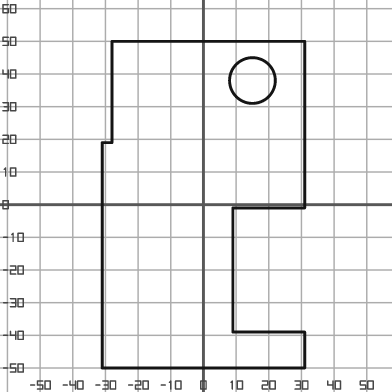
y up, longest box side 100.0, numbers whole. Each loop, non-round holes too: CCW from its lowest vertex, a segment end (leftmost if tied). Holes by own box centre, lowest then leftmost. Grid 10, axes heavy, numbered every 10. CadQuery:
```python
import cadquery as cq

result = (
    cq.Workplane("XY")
    .moveTo(-31.0, -50.0)
    .lineTo(31.0, -50.0)
    .lineTo(31.0, -39.0)
    .lineTo(9.0, -39.0)
    .lineTo(9.0, -1.0)
    .lineTo(31.0, -1.0)
    .lineTo(31.0, 50.0)
    .lineTo(-28.0, 50.0)
    .lineTo(-28.0, 19.0)
    .lineTo(-31.0, 19.0)
    .close()
    .moveTo(15.0, 38.0)
    .circle(7.0)
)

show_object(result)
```